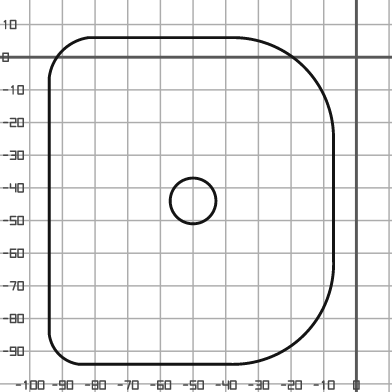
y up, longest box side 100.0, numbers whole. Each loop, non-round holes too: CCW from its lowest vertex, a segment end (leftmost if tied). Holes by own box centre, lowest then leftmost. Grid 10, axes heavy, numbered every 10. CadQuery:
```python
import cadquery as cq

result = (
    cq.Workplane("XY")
    .moveTo(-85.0, -94.0)
    .lineTo(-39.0, -94.0)
    .threePointArc((-16.0, -85.0), (-7.0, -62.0))
    .lineTo(-7.0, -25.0)
    .threePointArc((-16.0, -3.0), (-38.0, 6.0))
    .lineTo(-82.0, 6.0)
    .threePointArc((-90.0, 2.0), (-94.0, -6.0))
    .lineTo(-94.0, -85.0)
    .threePointArc((-91.0, -91.0), (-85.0, -94.0))
    .close()
    .moveTo(-50.0, -44.0)
    .circle(7.0)
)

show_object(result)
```